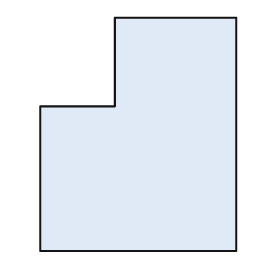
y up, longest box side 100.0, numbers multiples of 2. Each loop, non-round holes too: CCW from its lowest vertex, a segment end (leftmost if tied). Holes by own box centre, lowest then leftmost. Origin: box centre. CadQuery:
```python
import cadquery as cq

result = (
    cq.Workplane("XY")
    .moveTo(-42.0, -50.0)
    .lineTo(42.0, -50.0)
    .lineTo(42.0, 50.0)
    .lineTo(-10.0, 50.0)
    .lineTo(-10.0, 12.0)
    .lineTo(-42.0, 12.0)
    .close()
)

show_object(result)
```